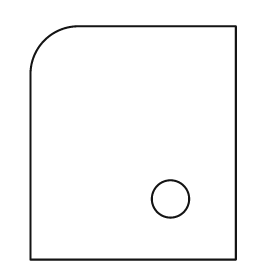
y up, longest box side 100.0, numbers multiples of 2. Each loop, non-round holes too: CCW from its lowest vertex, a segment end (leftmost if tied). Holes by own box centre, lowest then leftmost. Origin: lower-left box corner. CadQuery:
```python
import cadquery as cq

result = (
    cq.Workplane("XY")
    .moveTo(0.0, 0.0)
    .lineTo(88.0, 0.0)
    .lineTo(88.0, 100.0)
    .lineTo(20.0, 100.0)
    .threePointArc((6.0, 94.0), (0.0, 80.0))
    .close()
    .moveTo(60.0, 26.0)
    .circle(8.0)
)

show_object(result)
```